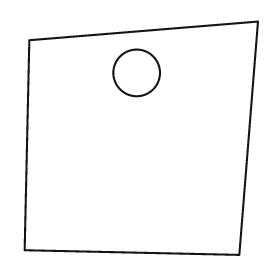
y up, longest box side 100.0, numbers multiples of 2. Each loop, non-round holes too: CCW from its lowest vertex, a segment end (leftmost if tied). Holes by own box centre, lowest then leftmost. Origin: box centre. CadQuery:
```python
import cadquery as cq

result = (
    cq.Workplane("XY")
    .moveTo(42.0, -50.0)
    .lineTo(50.0, 50.0)
    .lineTo(-48.0, 42.0)
    .lineTo(-50.0, -48.0)
    .close()
    .moveTo(-2.0, 28.0)
    .circle(10.0)
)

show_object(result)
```